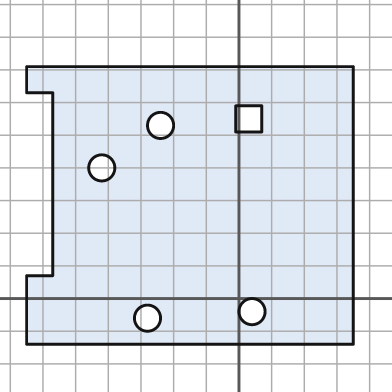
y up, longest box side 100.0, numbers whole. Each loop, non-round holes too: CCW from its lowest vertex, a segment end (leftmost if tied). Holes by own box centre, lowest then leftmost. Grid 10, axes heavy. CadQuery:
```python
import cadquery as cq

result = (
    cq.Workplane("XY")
    .moveTo(-65.0, -14.0)
    .lineTo(35.0, -14.0)
    .lineTo(35.0, 71.0)
    .lineTo(-65.0, 71.0)
    .lineTo(-65.0, 63.0)
    .lineTo(-57.0, 63.0)
    .lineTo(-57.0, 7.0)
    .lineTo(-65.0, 7.0)
    .close()
    .moveTo(-28.0, -6.0)
    .circle(4.0)
    .moveTo(4.0, -4.0)
    .circle(4.0)
    .moveTo(-42.0, 40.0)
    .circle(4.0)
    .moveTo(-24.0, 53.0)
    .circle(4.0)
    .moveTo(-1.0, 51.0)
    .lineTo(7.0, 51.0)
    .lineTo(7.0, 59.0)
    .lineTo(-1.0, 59.0)
    .close()
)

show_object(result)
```